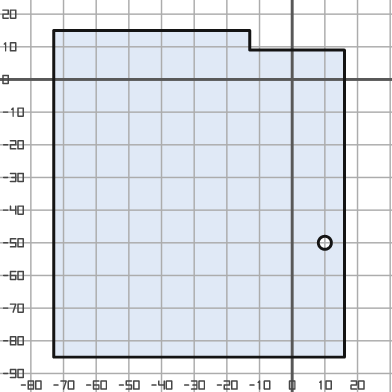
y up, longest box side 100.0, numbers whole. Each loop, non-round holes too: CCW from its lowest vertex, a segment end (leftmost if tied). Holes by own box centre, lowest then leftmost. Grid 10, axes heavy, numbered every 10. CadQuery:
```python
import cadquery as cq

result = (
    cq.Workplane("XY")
    .moveTo(-73.0, -85.0)
    .lineTo(16.0, -85.0)
    .lineTo(16.0, 9.0)
    .lineTo(-13.0, 9.0)
    .lineTo(-13.0, 15.0)
    .lineTo(-73.0, 15.0)
    .close()
    .moveTo(10.0, -50.0)
    .circle(2.0)
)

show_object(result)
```